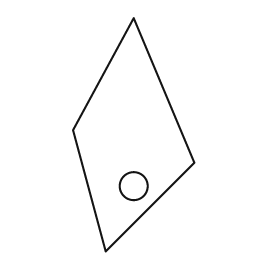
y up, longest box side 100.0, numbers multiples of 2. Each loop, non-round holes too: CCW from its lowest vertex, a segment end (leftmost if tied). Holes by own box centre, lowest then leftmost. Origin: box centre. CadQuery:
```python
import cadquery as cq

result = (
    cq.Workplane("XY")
    .moveTo(-12.0, -50.0)
    .lineTo(26.0, -12.0)
    .lineTo(0.0, 50.0)
    .lineTo(-26.0, 2.0)
    .close()
    .moveTo(0.0, -22.0)
    .circle(6.0)
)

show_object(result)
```